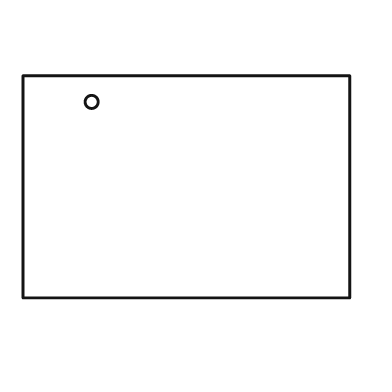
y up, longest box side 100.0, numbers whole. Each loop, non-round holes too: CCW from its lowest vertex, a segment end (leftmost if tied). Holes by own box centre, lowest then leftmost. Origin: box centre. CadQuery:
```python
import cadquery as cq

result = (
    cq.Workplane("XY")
    .moveTo(-50.0, -34.0)
    .lineTo(50.0, -34.0)
    .lineTo(50.0, 34.0)
    .lineTo(-50.0, 34.0)
    .close()
    .moveTo(-29.0, 26.0)
    .circle(2.0)
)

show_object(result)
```